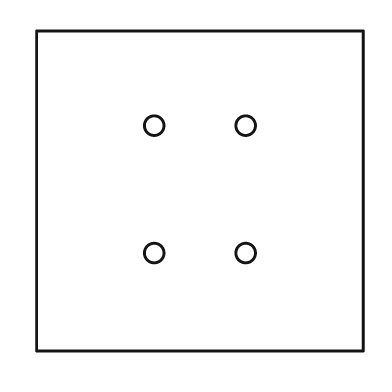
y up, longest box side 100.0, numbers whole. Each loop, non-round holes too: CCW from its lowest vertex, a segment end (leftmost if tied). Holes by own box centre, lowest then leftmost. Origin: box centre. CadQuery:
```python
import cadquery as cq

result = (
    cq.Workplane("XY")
    .moveTo(-50.0, -49.0)
    .lineTo(50.0, -49.0)
    .lineTo(50.0, 49.0)
    .lineTo(-50.0, 49.0)
    .close()
    .moveTo(-14.0, -19.0)
    .circle(3.0)
    .moveTo(14.0, -19.0)
    .circle(3.0)
    .moveTo(-14.0, 20.0)
    .circle(3.0)
    .moveTo(14.0, 20.0)
    .circle(3.0)
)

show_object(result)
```